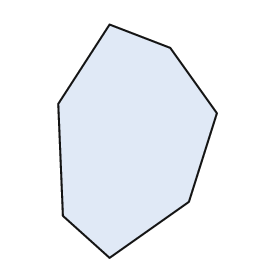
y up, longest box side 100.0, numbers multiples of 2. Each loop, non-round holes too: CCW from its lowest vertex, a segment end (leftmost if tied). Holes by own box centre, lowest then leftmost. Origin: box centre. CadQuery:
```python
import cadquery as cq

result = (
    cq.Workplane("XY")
    .moveTo(-12.0, -50.0)
    .lineTo(22.0, -26.0)
    .lineTo(34.0, 12.0)
    .lineTo(14.0, 40.0)
    .lineTo(-12.0, 50.0)
    .lineTo(-34.0, 16.0)
    .lineTo(-32.0, -32.0)
    .close()
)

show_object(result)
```